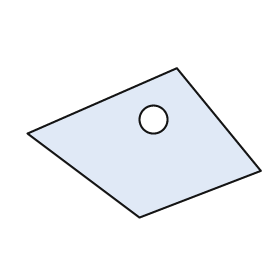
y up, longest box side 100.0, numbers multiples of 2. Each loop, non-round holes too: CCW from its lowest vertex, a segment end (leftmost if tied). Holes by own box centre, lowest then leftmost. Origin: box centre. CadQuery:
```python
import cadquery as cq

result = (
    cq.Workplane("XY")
    .moveTo(-2.0, -32.0)
    .lineTo(50.0, -12.0)
    .lineTo(14.0, 32.0)
    .lineTo(-50.0, 4.0)
    .close()
    .moveTo(4.0, 10.0)
    .circle(6.0)
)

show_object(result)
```